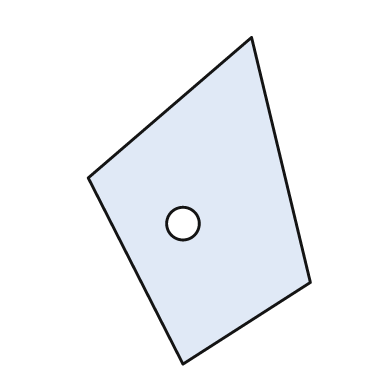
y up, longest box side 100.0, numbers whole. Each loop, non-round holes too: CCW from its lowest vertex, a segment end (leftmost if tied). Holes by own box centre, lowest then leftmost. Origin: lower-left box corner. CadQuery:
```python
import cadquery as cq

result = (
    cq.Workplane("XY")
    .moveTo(29.0, 0.0)
    .lineTo(68.0, 25.0)
    .lineTo(50.0, 100.0)
    .lineTo(0.0, 57.0)
    .close()
    .moveTo(29.0, 43.0)
    .circle(5.0)
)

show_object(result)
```